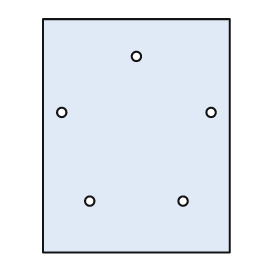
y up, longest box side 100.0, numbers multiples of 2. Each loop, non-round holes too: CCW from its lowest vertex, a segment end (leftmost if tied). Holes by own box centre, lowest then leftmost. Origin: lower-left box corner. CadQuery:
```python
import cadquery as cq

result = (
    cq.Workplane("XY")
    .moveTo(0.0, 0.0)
    .lineTo(80.0, 0.0)
    .lineTo(80.0, 100.0)
    .lineTo(0.0, 100.0)
    .close()
    .moveTo(20.0, 22.0)
    .circle(2.0)
    .moveTo(60.0, 22.0)
    .circle(2.0)
    .moveTo(8.0, 60.0)
    .circle(2.0)
    .moveTo(72.0, 60.0)
    .circle(2.0)
    .moveTo(40.0, 84.0)
    .circle(2.0)
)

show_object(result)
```